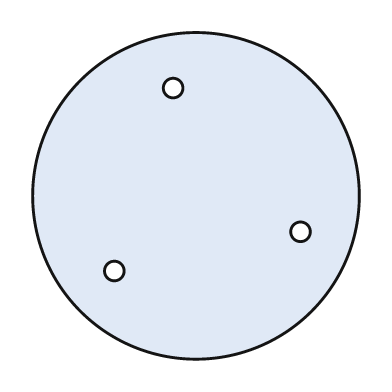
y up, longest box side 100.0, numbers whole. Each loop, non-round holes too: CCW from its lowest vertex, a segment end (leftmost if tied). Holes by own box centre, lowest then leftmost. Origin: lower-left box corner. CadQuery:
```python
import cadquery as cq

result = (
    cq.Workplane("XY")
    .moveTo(50.0, 50.0)
    .circle(50.0)
    .moveTo(25.0, 27.0)
    .circle(3.0)
    .moveTo(82.0, 39.0)
    .circle(3.0)
    .moveTo(43.0, 83.0)
    .circle(3.0)
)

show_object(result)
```